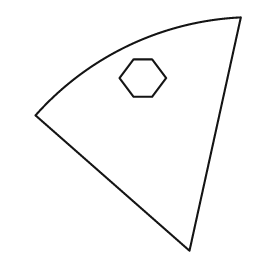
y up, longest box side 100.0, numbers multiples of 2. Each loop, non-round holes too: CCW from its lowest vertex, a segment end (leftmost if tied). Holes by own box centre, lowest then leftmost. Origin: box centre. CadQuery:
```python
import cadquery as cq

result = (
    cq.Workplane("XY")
    .moveTo(22.0, -50.0)
    .lineTo(44.0, 50.0)
    .threePointArc((-4.0, 38.0), (-44.0, 8.0))
    .close()
    .moveTo(-2.0, 16.0)
    .lineTo(6.0, 16.0)
    .lineTo(12.0, 24.0)
    .lineTo(6.0, 32.0)
    .lineTo(-2.0, 32.0)
    .lineTo(-8.0, 24.0)
    .close()
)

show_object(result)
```